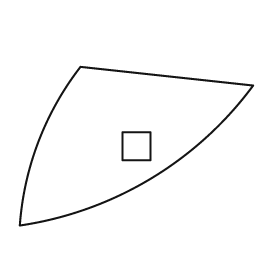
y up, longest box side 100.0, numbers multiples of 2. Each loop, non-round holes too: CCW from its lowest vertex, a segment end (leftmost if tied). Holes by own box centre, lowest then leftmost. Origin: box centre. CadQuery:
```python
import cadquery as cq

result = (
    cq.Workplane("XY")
    .moveTo(-50.0, -34.0)
    .threePointArc((6.0, -14.0), (50.0, 26.0))
    .lineTo(-24.0, 34.0)
    .threePointArc((-42.0, 2.0), (-50.0, -34.0))
    .close()
    .moveTo(-6.0, -6.0)
    .lineTo(6.0, -6.0)
    .lineTo(6.0, 6.0)
    .lineTo(-6.0, 6.0)
    .close()
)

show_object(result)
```